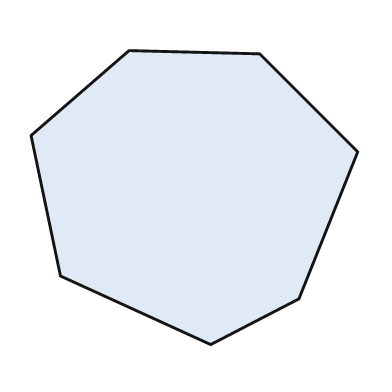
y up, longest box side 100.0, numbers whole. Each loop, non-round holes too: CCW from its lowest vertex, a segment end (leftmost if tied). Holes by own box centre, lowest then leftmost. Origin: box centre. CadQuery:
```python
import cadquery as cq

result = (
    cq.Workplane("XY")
    .moveTo(5.0, -45.0)
    .lineTo(32.0, -31.0)
    .lineTo(50.0, 14.0)
    .lineTo(20.0, 44.0)
    .lineTo(-20.0, 45.0)
    .lineTo(-50.0, 19.0)
    .lineTo(-41.0, -24.0)
    .close()
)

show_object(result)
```